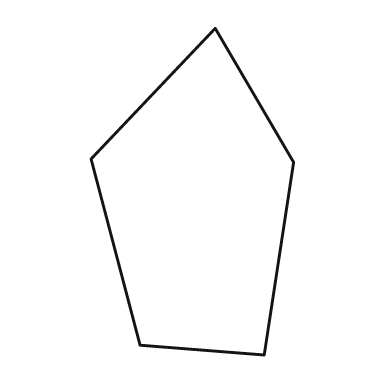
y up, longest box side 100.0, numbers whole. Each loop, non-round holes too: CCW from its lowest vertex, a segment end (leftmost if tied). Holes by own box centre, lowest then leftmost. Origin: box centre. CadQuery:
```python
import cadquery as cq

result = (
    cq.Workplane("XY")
    .moveTo(22.0, -50.0)
    .lineTo(31.0, 9.0)
    .lineTo(7.0, 50.0)
    .lineTo(-31.0, 10.0)
    .lineTo(-16.0, -47.0)
    .close()
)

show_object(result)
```